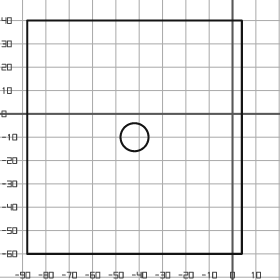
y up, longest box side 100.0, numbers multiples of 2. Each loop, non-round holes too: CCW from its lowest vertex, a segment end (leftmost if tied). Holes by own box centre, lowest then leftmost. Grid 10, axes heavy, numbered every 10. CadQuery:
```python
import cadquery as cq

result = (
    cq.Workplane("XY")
    .moveTo(-88.0, -60.0)
    .lineTo(4.0, -60.0)
    .lineTo(4.0, 40.0)
    .lineTo(-88.0, 40.0)
    .close()
    .moveTo(-42.0, -10.0)
    .circle(6.0)
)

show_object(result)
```